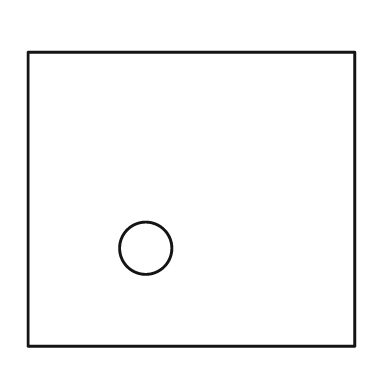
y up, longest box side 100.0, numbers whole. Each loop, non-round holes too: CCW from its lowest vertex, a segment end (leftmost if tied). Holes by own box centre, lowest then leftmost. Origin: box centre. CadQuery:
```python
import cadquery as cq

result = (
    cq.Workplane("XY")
    .moveTo(-50.0, -45.0)
    .lineTo(50.0, -45.0)
    .lineTo(50.0, 45.0)
    .lineTo(-50.0, 45.0)
    .close()
    .moveTo(-14.0, -15.0)
    .circle(8.0)
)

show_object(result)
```